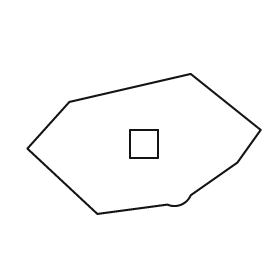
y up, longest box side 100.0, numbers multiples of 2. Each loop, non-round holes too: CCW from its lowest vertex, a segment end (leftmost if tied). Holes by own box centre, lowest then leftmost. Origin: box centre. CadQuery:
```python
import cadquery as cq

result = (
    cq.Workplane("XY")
    .moveTo(-20.0, -30.0)
    .lineTo(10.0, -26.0)
    .threePointArc((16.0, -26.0), (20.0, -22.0))
    .lineTo(40.0, -8.0)
    .lineTo(50.0, 6.0)
    .lineTo(20.0, 30.0)
    .lineTo(-32.0, 18.0)
    .lineTo(-50.0, -2.0)
    .close()
    .moveTo(-6.0, -6.0)
    .lineTo(6.0, -6.0)
    .lineTo(6.0, 6.0)
    .lineTo(-6.0, 6.0)
    .close()
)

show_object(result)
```